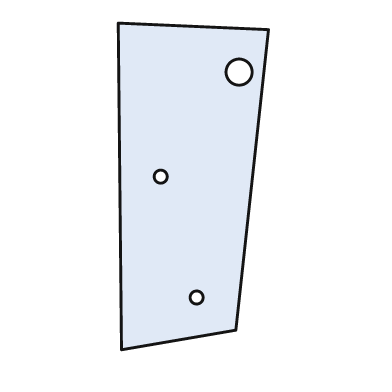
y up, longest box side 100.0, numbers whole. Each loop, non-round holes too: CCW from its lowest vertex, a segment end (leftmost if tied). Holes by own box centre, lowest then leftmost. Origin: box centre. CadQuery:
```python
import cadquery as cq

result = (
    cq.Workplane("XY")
    .moveTo(-22.0, -50.0)
    .lineTo(13.0, -44.0)
    .lineTo(23.0, 48.0)
    .lineTo(-23.0, 50.0)
    .close()
    .moveTo(1.0, -34.0)
    .circle(2.0)
    .moveTo(-10.0, 3.0)
    .circle(2.0)
    .moveTo(14.0, 35.0)
    .circle(4.0)
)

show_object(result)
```